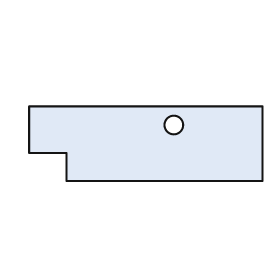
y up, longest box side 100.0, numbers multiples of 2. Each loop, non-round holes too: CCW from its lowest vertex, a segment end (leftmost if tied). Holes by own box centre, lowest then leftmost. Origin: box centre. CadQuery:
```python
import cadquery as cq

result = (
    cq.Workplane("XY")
    .moveTo(-34.0, -16.0)
    .lineTo(50.0, -16.0)
    .lineTo(50.0, 16.0)
    .lineTo(-50.0, 16.0)
    .lineTo(-50.0, -4.0)
    .lineTo(-34.0, -4.0)
    .close()
    .moveTo(12.0, 8.0)
    .circle(4.0)
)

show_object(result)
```